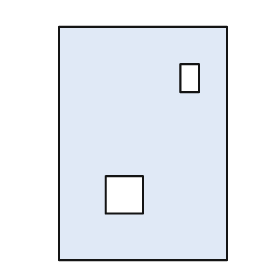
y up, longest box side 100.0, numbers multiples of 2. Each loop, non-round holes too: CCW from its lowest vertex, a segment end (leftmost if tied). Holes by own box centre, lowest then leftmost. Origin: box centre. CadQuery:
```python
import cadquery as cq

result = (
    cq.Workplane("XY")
    .moveTo(-36.0, -50.0)
    .lineTo(36.0, -50.0)
    .lineTo(36.0, 50.0)
    .lineTo(-36.0, 50.0)
    .close()
    .moveTo(-16.0, -30.0)
    .lineTo(0.0, -30.0)
    .lineTo(0.0, -14.0)
    .lineTo(-16.0, -14.0)
    .close()
    .moveTo(16.0, 22.0)
    .lineTo(24.0, 22.0)
    .lineTo(24.0, 34.0)
    .lineTo(16.0, 34.0)
    .close()
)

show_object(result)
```